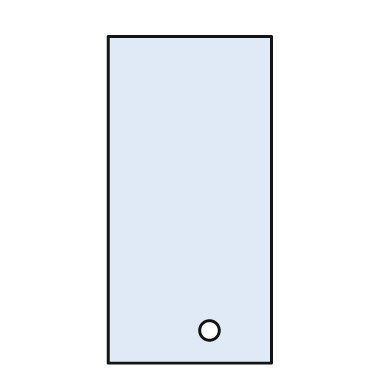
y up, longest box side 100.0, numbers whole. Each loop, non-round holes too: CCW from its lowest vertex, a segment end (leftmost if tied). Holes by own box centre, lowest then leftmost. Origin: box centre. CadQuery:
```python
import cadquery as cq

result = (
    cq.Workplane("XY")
    .moveTo(-25.0, -50.0)
    .lineTo(25.0, -50.0)
    .lineTo(25.0, 50.0)
    .lineTo(-25.0, 50.0)
    .close()
    .moveTo(6.0, -40.0)
    .circle(3.0)
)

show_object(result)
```